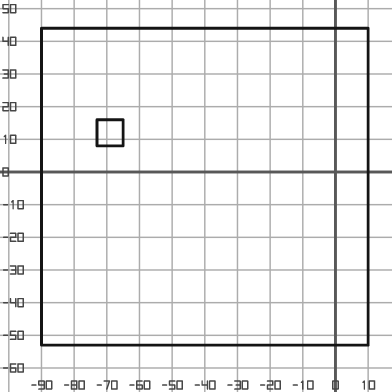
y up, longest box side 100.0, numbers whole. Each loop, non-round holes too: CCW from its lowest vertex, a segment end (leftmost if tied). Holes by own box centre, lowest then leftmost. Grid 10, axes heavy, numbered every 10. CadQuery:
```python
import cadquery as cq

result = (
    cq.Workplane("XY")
    .moveTo(-90.0, -53.0)
    .lineTo(10.0, -53.0)
    .lineTo(10.0, 44.0)
    .lineTo(-90.0, 44.0)
    .close()
    .moveTo(-73.0, 8.0)
    .lineTo(-65.0, 8.0)
    .lineTo(-65.0, 16.0)
    .lineTo(-73.0, 16.0)
    .close()
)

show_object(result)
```